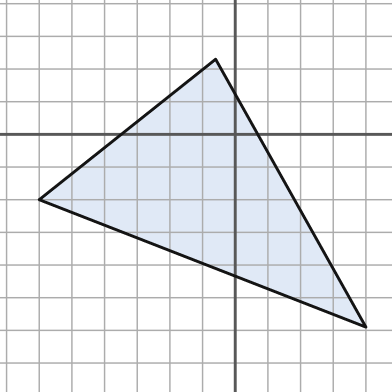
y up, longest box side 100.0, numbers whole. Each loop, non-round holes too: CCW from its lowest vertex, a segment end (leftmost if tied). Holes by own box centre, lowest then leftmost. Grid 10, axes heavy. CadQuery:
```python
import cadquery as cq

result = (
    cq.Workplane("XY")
    .moveTo(40.0, -59.0)
    .lineTo(-6.0, 23.0)
    .lineTo(-60.0, -20.0)
    .close()
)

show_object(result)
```